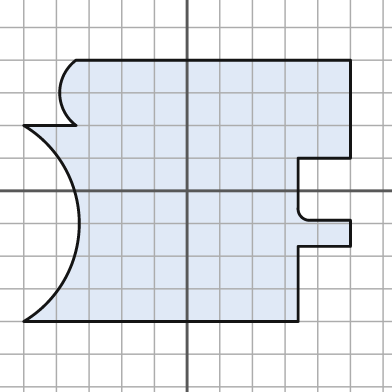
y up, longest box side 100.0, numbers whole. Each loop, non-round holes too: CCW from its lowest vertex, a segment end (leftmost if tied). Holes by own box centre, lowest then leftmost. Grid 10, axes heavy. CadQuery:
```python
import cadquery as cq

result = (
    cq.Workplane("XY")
    .moveTo(-50.0, -40.0)
    .lineTo(34.0, -40.0)
    .lineTo(34.0, -17.0)
    .lineTo(50.0, -17.0)
    .lineTo(50.0, -9.0)
    .lineTo(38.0, -9.0)
    .threePointArc((35.0, -8.0), (34.0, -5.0))
    .lineTo(34.0, 10.0)
    .lineTo(50.0, 10.0)
    .lineTo(50.0, 40.0)
    .lineTo(-34.0, 40.0)
    .threePointArc((-39.0, 30.0), (-34.0, 20.0))
    .lineTo(-50.0, 20.0)
    .threePointArc((-33.0, -10.0), (-50.0, -40.0))
    .close()
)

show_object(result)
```